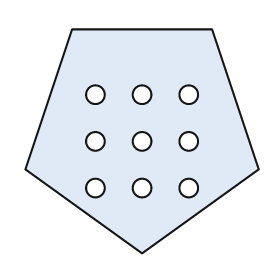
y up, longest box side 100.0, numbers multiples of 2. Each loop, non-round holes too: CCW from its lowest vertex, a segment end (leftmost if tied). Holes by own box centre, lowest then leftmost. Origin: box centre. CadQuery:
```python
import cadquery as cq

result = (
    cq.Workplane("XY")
    .moveTo(0.0, -48.0)
    .lineTo(50.0, -12.0)
    .lineTo(30.0, 48.0)
    .lineTo(-30.0, 48.0)
    .lineTo(-50.0, -12.0)
    .close()
    .moveTo(-20.0, -20.0)
    .circle(4.0)
    .moveTo(0.0, -20.0)
    .circle(4.0)
    .moveTo(20.0, -20.0)
    .circle(4.0)
    .moveTo(-20.0, 0.0)
    .circle(4.0)
    .moveTo(0.0, 0.0)
    .circle(4.0)
    .moveTo(20.0, 0.0)
    .circle(4.0)
    .moveTo(-20.0, 20.0)
    .circle(4.0)
    .moveTo(0.0, 20.0)
    .circle(4.0)
    .moveTo(20.0, 20.0)
    .circle(4.0)
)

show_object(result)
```